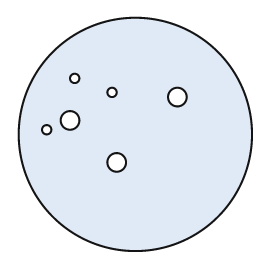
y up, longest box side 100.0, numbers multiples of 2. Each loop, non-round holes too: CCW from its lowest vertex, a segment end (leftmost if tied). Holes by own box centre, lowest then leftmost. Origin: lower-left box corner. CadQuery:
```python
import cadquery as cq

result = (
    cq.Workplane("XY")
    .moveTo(50.0, 50.0)
    .circle(50.0)
    .moveTo(42.0, 38.0)
    .circle(4.0)
    .moveTo(12.0, 52.0)
    .circle(2.0)
    .moveTo(22.0, 56.0)
    .circle(4.0)
    .moveTo(68.0, 66.0)
    .circle(4.0)
    .moveTo(40.0, 68.0)
    .circle(2.0)
    .moveTo(24.0, 74.0)
    .circle(2.0)
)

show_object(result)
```